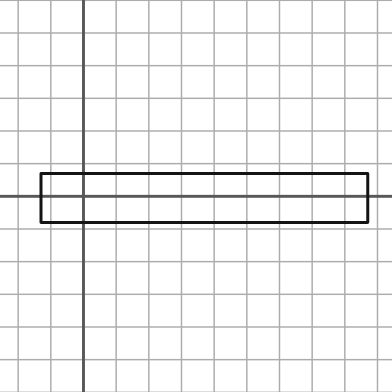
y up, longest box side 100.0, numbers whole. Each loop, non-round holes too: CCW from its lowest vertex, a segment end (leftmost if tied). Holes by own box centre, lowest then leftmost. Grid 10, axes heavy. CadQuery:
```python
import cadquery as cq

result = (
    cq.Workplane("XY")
    .moveTo(-13.0, -8.0)
    .lineTo(87.0, -8.0)
    .lineTo(87.0, 7.0)
    .lineTo(-13.0, 7.0)
    .close()
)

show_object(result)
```